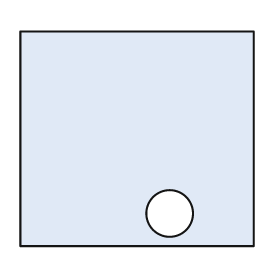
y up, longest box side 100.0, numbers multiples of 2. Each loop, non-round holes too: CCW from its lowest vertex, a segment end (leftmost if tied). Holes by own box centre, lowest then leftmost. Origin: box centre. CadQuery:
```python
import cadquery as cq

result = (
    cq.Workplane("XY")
    .moveTo(-50.0, -46.0)
    .lineTo(50.0, -46.0)
    .lineTo(50.0, 46.0)
    .lineTo(-50.0, 46.0)
    .close()
    .moveTo(14.0, -32.0)
    .circle(10.0)
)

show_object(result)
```